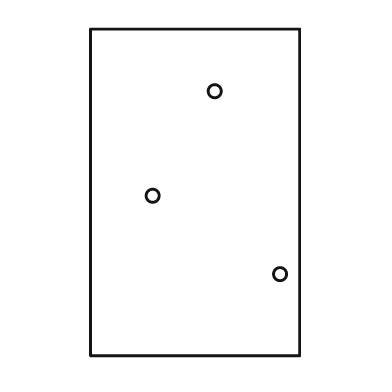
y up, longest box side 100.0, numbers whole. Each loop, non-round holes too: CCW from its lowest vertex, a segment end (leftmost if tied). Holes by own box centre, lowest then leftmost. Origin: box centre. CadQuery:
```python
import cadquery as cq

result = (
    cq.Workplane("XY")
    .moveTo(-32.0, -50.0)
    .lineTo(32.0, -50.0)
    .lineTo(32.0, 50.0)
    .lineTo(-32.0, 50.0)
    .close()
    .moveTo(26.0, -25.0)
    .circle(2.0)
    .moveTo(-13.0, -1.0)
    .circle(2.0)
    .moveTo(6.0, 31.0)
    .circle(2.0)
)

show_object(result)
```